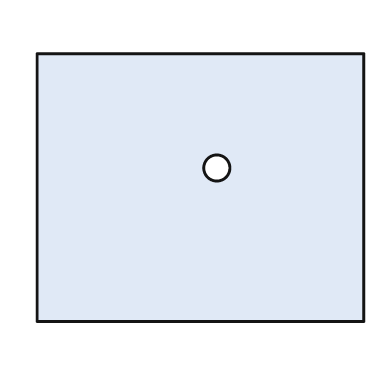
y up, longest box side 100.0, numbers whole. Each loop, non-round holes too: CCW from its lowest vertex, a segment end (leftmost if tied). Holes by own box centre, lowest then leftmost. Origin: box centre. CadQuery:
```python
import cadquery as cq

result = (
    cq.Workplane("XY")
    .moveTo(-50.0, -41.0)
    .lineTo(50.0, -41.0)
    .lineTo(50.0, 41.0)
    .lineTo(-50.0, 41.0)
    .close()
    .moveTo(5.0, 6.0)
    .circle(4.0)
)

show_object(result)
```